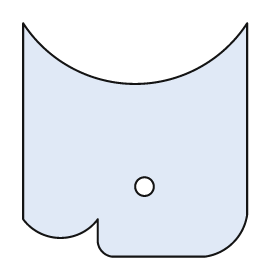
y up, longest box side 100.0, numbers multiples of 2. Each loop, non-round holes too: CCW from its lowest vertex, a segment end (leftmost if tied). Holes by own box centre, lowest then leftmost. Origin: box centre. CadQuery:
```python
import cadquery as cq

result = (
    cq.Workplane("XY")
    .moveTo(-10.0, -50.0)
    .lineTo(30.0, -50.0)
    .threePointArc((42.0, -44.0), (48.0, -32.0))
    .lineTo(48.0, 50.0)
    .threePointArc((0.0, 24.0), (-48.0, 50.0))
    .lineTo(-48.0, -34.0)
    .threePointArc((-32.0, -42.0), (-16.0, -34.0))
    .lineTo(-16.0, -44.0)
    .threePointArc((-14.0, -48.0), (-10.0, -50.0))
    .close()
    .moveTo(4.0, -20.0)
    .circle(4.0)
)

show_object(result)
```